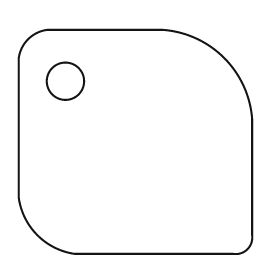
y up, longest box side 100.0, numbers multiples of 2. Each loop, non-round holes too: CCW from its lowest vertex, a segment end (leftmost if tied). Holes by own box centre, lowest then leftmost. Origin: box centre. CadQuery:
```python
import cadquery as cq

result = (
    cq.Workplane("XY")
    .moveTo(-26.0, -48.0)
    .lineTo(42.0, -48.0)
    .threePointArc((48.0, -46.0), (50.0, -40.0))
    .lineTo(50.0, 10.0)
    .threePointArc((38.0, 36.0), (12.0, 48.0))
    .lineTo(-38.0, 48.0)
    .threePointArc((-46.0, 44.0), (-50.0, 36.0))
    .lineTo(-50.0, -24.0)
    .threePointArc((-42.0, -40.0), (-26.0, -48.0))
    .close()
    .moveTo(-30.0, 26.0)
    .circle(8.0)
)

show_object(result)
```